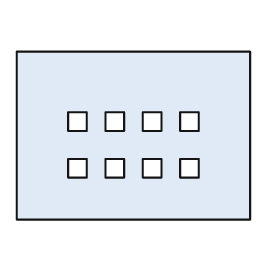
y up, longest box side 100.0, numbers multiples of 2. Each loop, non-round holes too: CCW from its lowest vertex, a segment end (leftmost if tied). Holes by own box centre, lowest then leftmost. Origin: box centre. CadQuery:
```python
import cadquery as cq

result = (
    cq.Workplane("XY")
    .moveTo(-50.0, -36.0)
    .lineTo(50.0, -36.0)
    .lineTo(50.0, 36.0)
    .lineTo(-50.0, 36.0)
    .close()
    .moveTo(-28.0, -18.0)
    .lineTo(-20.0, -18.0)
    .lineTo(-20.0, -10.0)
    .lineTo(-28.0, -10.0)
    .close()
    .moveTo(-12.0, -18.0)
    .lineTo(-4.0, -18.0)
    .lineTo(-4.0, -10.0)
    .lineTo(-12.0, -10.0)
    .close()
    .moveTo(4.0, -18.0)
    .lineTo(12.0, -18.0)
    .lineTo(12.0, -10.0)
    .lineTo(4.0, -10.0)
    .close()
    .moveTo(20.0, -18.0)
    .lineTo(28.0, -18.0)
    .lineTo(28.0, -10.0)
    .lineTo(20.0, -10.0)
    .close()
    .moveTo(-28.0, 2.0)
    .lineTo(-20.0, 2.0)
    .lineTo(-20.0, 10.0)
    .lineTo(-28.0, 10.0)
    .close()
    .moveTo(-12.0, 2.0)
    .lineTo(-4.0, 2.0)
    .lineTo(-4.0, 10.0)
    .lineTo(-12.0, 10.0)
    .close()
    .moveTo(4.0, 2.0)
    .lineTo(12.0, 2.0)
    .lineTo(12.0, 10.0)
    .lineTo(4.0, 10.0)
    .close()
    .moveTo(20.0, 2.0)
    .lineTo(28.0, 2.0)
    .lineTo(28.0, 10.0)
    .lineTo(20.0, 10.0)
    .close()
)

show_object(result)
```